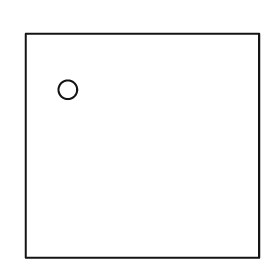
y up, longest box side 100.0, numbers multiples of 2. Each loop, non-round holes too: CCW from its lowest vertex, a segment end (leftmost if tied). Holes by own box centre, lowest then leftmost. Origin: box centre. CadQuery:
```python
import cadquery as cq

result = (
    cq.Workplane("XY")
    .moveTo(-50.0, -48.0)
    .lineTo(50.0, -48.0)
    .lineTo(50.0, 48.0)
    .lineTo(-50.0, 48.0)
    .close()
    .moveTo(-32.0, 24.0)
    .circle(4.0)
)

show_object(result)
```